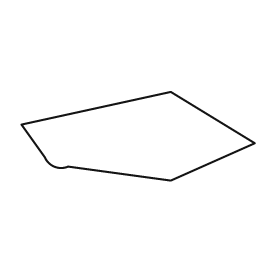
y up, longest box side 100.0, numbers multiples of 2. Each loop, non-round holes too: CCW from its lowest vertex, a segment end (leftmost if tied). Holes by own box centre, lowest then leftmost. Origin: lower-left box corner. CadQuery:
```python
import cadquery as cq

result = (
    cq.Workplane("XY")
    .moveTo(64.0, 0.0)
    .lineTo(100.0, 16.0)
    .lineTo(64.0, 38.0)
    .lineTo(0.0, 24.0)
    .lineTo(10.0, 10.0)
    .threePointArc((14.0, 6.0), (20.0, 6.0))
    .close()
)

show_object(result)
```